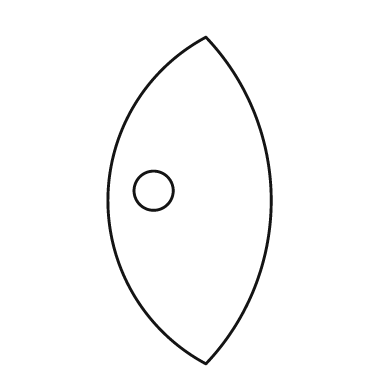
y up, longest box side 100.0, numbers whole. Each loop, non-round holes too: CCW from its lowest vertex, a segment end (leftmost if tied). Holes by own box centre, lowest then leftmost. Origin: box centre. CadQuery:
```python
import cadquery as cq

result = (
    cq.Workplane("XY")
    .moveTo(5.0, -50.0)
    .threePointArc((25.0, 0.0), (5.0, 50.0))
    .threePointArc((-25.0, 0.0), (5.0, -50.0))
    .close()
    .moveTo(-11.0, 3.0)
    .circle(6.0)
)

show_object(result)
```